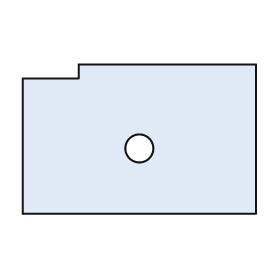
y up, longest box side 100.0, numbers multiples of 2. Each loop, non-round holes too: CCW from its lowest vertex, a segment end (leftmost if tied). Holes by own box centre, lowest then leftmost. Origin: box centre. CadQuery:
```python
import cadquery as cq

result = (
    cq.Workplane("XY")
    .moveTo(-50.0, -32.0)
    .lineTo(50.0, -32.0)
    .lineTo(50.0, 32.0)
    .lineTo(-26.0, 32.0)
    .lineTo(-26.0, 26.0)
    .lineTo(-50.0, 26.0)
    .close()
    .moveTo(0.0, -4.0)
    .circle(6.0)
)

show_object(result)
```